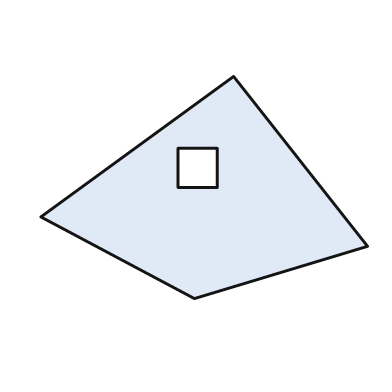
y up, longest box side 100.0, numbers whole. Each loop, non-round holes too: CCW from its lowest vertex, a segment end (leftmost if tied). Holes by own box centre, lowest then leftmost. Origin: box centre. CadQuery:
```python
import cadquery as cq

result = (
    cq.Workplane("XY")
    .moveTo(-3.0, -34.0)
    .lineTo(50.0, -18.0)
    .lineTo(9.0, 34.0)
    .lineTo(-50.0, -9.0)
    .close()
    .moveTo(-8.0, 0.0)
    .lineTo(4.0, 0.0)
    .lineTo(4.0, 12.0)
    .lineTo(-8.0, 12.0)
    .close()
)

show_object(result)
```